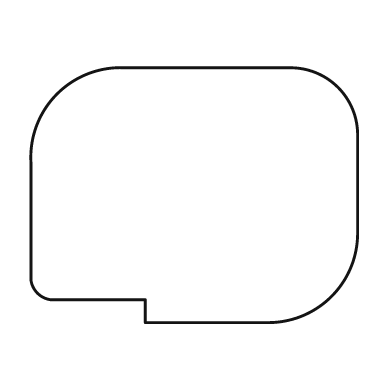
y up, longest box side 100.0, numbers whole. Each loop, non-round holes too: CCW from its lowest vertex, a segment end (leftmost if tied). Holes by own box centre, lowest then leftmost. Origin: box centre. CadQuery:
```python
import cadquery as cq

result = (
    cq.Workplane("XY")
    .moveTo(-15.0, -39.0)
    .lineTo(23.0, -39.0)
    .threePointArc((42.0, -31.0), (50.0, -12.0))
    .lineTo(50.0, 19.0)
    .threePointArc((44.0, 33.0), (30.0, 39.0))
    .lineTo(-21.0, 39.0)
    .threePointArc((-42.0, 31.0), (-50.0, 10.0))
    .lineTo(-50.0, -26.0)
    .threePointArc((-48.0, -30.0), (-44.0, -32.0))
    .lineTo(-15.0, -32.0)
    .close()
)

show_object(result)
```